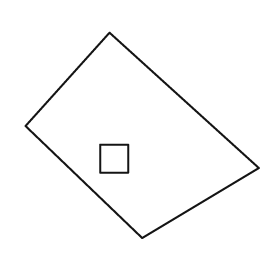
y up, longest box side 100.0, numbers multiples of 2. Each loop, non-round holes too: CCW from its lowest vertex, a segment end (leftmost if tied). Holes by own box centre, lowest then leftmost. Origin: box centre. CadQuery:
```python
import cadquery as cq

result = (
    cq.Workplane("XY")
    .moveTo(0.0, -44.0)
    .lineTo(50.0, -14.0)
    .lineTo(-14.0, 44.0)
    .lineTo(-50.0, 4.0)
    .close()
    .moveTo(-18.0, -16.0)
    .lineTo(-6.0, -16.0)
    .lineTo(-6.0, -4.0)
    .lineTo(-18.0, -4.0)
    .close()
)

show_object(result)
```